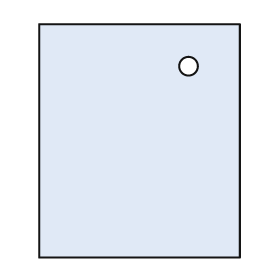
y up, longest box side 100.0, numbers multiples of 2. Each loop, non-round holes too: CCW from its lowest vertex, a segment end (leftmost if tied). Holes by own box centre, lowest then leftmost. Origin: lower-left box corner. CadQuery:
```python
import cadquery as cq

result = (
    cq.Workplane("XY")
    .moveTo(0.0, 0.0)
    .lineTo(86.0, 0.0)
    .lineTo(86.0, 100.0)
    .lineTo(0.0, 100.0)
    .close()
    .moveTo(64.0, 82.0)
    .circle(4.0)
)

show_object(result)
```